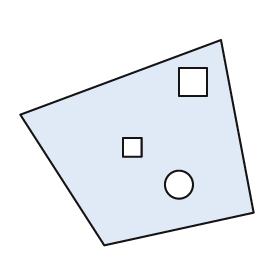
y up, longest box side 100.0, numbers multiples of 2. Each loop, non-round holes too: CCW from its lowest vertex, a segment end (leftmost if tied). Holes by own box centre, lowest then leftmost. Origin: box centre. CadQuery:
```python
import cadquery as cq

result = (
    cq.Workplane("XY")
    .moveTo(-14.0, -44.0)
    .lineTo(50.0, -30.0)
    .lineTo(36.0, 44.0)
    .lineTo(-50.0, 12.0)
    .close()
    .moveTo(18.0, -18.0)
    .circle(6.0)
    .moveTo(-6.0, -6.0)
    .lineTo(2.0, -6.0)
    .lineTo(2.0, 2.0)
    .lineTo(-6.0, 2.0)
    .close()
    .moveTo(18.0, 20.0)
    .lineTo(30.0, 20.0)
    .lineTo(30.0, 32.0)
    .lineTo(18.0, 32.0)
    .close()
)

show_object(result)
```